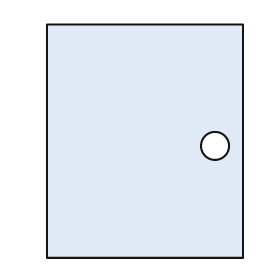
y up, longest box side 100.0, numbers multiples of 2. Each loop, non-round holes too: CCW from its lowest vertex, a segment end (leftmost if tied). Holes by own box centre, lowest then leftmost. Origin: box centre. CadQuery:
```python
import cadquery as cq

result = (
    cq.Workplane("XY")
    .moveTo(-42.0, -50.0)
    .lineTo(42.0, -50.0)
    .lineTo(42.0, 50.0)
    .lineTo(-42.0, 50.0)
    .close()
    .moveTo(30.0, -2.0)
    .circle(6.0)
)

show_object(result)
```